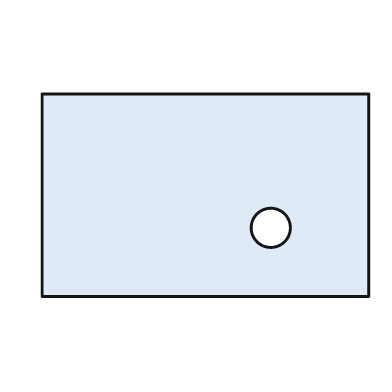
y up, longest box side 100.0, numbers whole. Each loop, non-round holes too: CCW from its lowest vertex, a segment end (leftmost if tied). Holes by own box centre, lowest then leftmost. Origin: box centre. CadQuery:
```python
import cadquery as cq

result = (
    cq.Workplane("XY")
    .moveTo(-50.0, -31.0)
    .lineTo(50.0, -31.0)
    .lineTo(50.0, 31.0)
    .lineTo(-50.0, 31.0)
    .close()
    .moveTo(20.0, -10.0)
    .circle(6.0)
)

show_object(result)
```